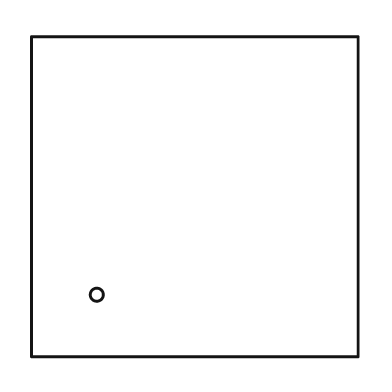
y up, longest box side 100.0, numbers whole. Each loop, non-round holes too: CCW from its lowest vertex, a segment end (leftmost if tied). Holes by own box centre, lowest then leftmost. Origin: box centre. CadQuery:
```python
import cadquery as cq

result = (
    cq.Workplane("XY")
    .moveTo(-50.0, -49.0)
    .lineTo(50.0, -49.0)
    .lineTo(50.0, 49.0)
    .lineTo(-50.0, 49.0)
    .close()
    .moveTo(-30.0, -30.0)
    .circle(2.0)
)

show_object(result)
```